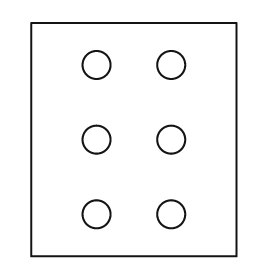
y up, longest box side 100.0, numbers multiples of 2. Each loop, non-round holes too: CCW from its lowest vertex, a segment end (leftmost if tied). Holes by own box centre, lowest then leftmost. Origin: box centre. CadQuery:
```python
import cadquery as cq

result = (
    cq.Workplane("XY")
    .moveTo(-44.0, -50.0)
    .lineTo(44.0, -50.0)
    .lineTo(44.0, 50.0)
    .lineTo(-44.0, 50.0)
    .close()
    .moveTo(-16.0, -32.0)
    .circle(6.0)
    .moveTo(16.0, -32.0)
    .circle(6.0)
    .moveTo(-16.0, 0.0)
    .circle(6.0)
    .moveTo(16.0, 0.0)
    .circle(6.0)
    .moveTo(-16.0, 32.0)
    .circle(6.0)
    .moveTo(16.0, 32.0)
    .circle(6.0)
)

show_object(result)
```